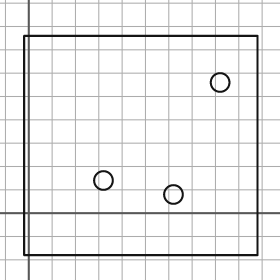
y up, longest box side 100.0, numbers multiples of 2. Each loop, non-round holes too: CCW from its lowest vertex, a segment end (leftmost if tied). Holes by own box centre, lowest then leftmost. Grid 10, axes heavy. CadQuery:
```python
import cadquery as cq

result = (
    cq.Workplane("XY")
    .moveTo(-2.0, -18.0)
    .lineTo(98.0, -18.0)
    .lineTo(98.0, 76.0)
    .lineTo(-2.0, 76.0)
    .close()
    .moveTo(62.0, 8.0)
    .circle(4.0)
    .moveTo(32.0, 14.0)
    .circle(4.0)
    .moveTo(82.0, 56.0)
    .circle(4.0)
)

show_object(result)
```